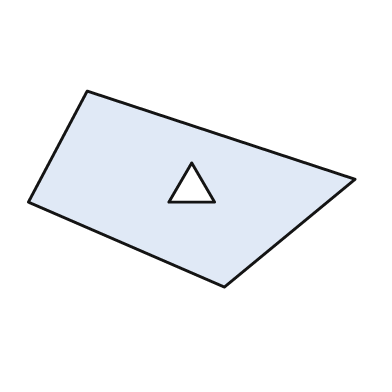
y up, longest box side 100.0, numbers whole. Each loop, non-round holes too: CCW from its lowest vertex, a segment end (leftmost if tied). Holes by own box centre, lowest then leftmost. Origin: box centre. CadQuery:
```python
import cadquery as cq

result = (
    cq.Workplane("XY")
    .moveTo(10.0, -30.0)
    .lineTo(50.0, 3.0)
    .lineTo(-32.0, 30.0)
    .lineTo(-50.0, -4.0)
    .close()
    .moveTo(-7.0, -4.0)
    .lineTo(7.0, -4.0)
    .lineTo(0.0, 8.0)
    .close()
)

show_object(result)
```